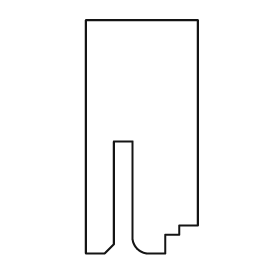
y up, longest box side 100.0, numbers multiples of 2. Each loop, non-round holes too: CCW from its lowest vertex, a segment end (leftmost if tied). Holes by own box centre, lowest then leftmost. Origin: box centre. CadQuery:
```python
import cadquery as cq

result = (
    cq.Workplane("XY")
    .moveTo(-24.0, -50.0)
    .lineTo(-16.0, -50.0)
    .lineTo(-12.0, -46.0)
    .lineTo(-12.0, -2.0)
    .lineTo(-4.0, -2.0)
    .lineTo(-4.0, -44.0)
    .threePointArc((-2.0, -48.0), (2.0, -50.0))
    .lineTo(10.0, -50.0)
    .lineTo(10.0, -42.0)
    .lineTo(16.0, -42.0)
    .lineTo(16.0, -38.0)
    .lineTo(24.0, -38.0)
    .lineTo(24.0, 50.0)
    .lineTo(-24.0, 50.0)
    .close()
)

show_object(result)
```